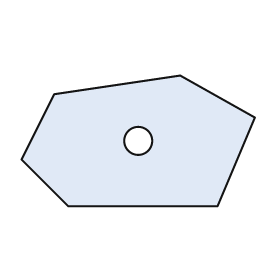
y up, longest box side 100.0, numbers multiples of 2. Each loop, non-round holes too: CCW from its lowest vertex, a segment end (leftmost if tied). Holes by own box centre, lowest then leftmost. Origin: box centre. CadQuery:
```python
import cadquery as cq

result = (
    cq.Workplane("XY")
    .moveTo(-30.0, -28.0)
    .lineTo(34.0, -28.0)
    .lineTo(50.0, 10.0)
    .lineTo(18.0, 28.0)
    .lineTo(-36.0, 20.0)
    .lineTo(-50.0, -8.0)
    .close()
    .moveTo(0.0, 0.0)
    .circle(6.0)
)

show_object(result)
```